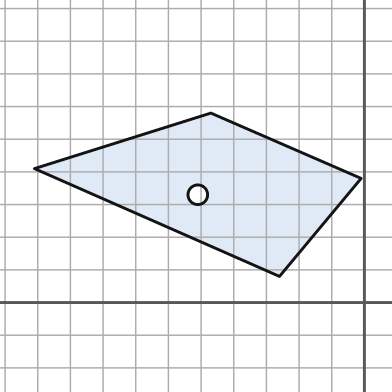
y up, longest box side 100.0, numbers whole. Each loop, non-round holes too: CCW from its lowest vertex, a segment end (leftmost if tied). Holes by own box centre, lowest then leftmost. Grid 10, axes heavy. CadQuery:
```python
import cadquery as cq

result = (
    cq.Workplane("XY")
    .moveTo(-26.0, 8.0)
    .lineTo(-1.0, 38.0)
    .lineTo(-47.0, 58.0)
    .lineTo(-101.0, 41.0)
    .close()
    .moveTo(-51.0, 33.0)
    .circle(3.0)
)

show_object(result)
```